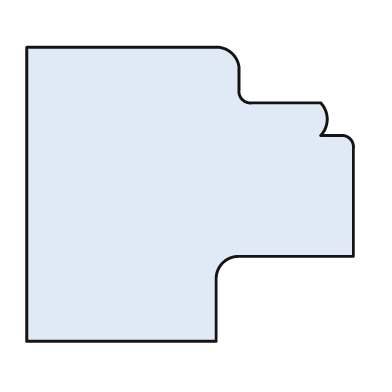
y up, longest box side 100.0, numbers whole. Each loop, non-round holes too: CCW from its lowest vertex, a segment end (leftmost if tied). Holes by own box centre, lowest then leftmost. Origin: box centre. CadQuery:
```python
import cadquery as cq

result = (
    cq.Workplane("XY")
    .moveTo(-50.0, -45.0)
    .lineTo(8.0, -45.0)
    .lineTo(8.0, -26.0)
    .threePointArc((10.0, -21.0), (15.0, -19.0))
    .lineTo(50.0, -19.0)
    .lineTo(50.0, 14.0)
    .threePointArc((49.0, 17.0), (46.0, 18.0))
    .lineTo(40.0, 18.0)
    .threePointArc((42.0, 23.0), (40.0, 28.0))
    .lineTo(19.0, 28.0)
    .threePointArc((16.0, 29.0), (15.0, 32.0))
    .lineTo(15.0, 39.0)
    .threePointArc((13.0, 43.0), (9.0, 45.0))
    .lineTo(-50.0, 45.0)
    .close()
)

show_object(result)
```